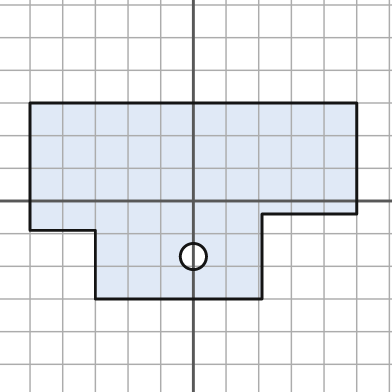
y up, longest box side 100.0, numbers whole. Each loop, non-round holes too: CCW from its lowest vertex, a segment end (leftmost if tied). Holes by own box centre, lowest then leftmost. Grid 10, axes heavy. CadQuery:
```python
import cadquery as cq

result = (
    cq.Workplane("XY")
    .moveTo(-30.0, -30.0)
    .lineTo(21.0, -30.0)
    .lineTo(21.0, -4.0)
    .lineTo(50.0, -4.0)
    .lineTo(50.0, 30.0)
    .lineTo(-50.0, 30.0)
    .lineTo(-50.0, -9.0)
    .lineTo(-30.0, -9.0)
    .close()
    .moveTo(0.0, -17.0)
    .circle(4.0)
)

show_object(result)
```